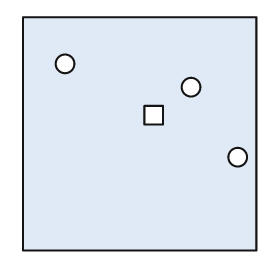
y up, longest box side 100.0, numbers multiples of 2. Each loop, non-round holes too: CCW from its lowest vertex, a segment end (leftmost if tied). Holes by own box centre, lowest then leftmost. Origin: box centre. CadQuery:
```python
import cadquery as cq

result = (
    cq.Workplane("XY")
    .moveTo(-50.0, -50.0)
    .lineTo(50.0, -50.0)
    .lineTo(50.0, 50.0)
    .lineTo(-50.0, 50.0)
    .close()
    .moveTo(42.0, -10.0)
    .circle(4.0)
    .moveTo(2.0, 4.0)
    .lineTo(10.0, 4.0)
    .lineTo(10.0, 12.0)
    .lineTo(2.0, 12.0)
    .close()
    .moveTo(22.0, 20.0)
    .circle(4.0)
    .moveTo(-32.0, 30.0)
    .circle(4.0)
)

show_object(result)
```